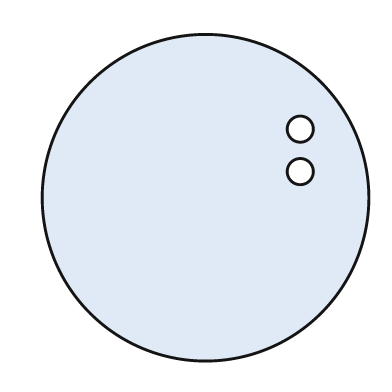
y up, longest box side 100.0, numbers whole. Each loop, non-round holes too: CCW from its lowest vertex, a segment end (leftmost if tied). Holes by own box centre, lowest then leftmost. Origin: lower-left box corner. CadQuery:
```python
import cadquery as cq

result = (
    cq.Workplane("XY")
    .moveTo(50.0, 50.0)
    .circle(50.0)
    .moveTo(79.0, 58.0)
    .circle(4.0)
    .moveTo(79.0, 71.0)
    .circle(4.0)
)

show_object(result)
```